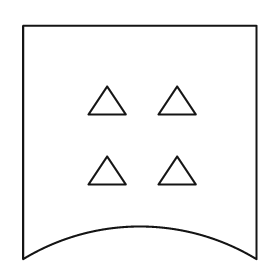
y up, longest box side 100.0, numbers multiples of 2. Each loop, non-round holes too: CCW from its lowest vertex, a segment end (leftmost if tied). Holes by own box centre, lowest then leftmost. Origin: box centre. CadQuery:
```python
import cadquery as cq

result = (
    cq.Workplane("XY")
    .moveTo(-50.0, -50.0)
    .threePointArc((0.0, -36.0), (50.0, -50.0))
    .lineTo(50.0, 50.0)
    .lineTo(-50.0, 50.0)
    .close()
    .moveTo(-22.0, -18.0)
    .lineTo(-6.0, -18.0)
    .lineTo(-14.0, -6.0)
    .close()
    .moveTo(8.0, -18.0)
    .lineTo(24.0, -18.0)
    .lineTo(16.0, -6.0)
    .close()
    .moveTo(-22.0, 12.0)
    .lineTo(-6.0, 12.0)
    .lineTo(-14.0, 24.0)
    .close()
    .moveTo(8.0, 12.0)
    .lineTo(24.0, 12.0)
    .lineTo(16.0, 24.0)
    .close()
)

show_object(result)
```